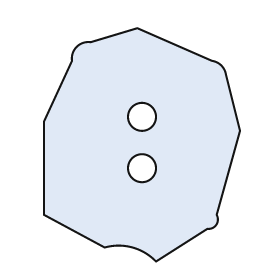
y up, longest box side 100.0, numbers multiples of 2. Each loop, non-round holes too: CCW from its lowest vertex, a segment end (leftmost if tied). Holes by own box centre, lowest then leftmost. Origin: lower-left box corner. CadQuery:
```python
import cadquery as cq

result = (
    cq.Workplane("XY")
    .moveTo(48.0, 0.0)
    .lineTo(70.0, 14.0)
    .threePointArc((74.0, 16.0), (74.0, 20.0))
    .lineTo(84.0, 56.0)
    .lineTo(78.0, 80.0)
    .threePointArc((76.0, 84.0), (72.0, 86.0))
    .lineTo(40.0, 100.0)
    .lineTo(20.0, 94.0)
    .threePointArc((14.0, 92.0), (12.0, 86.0))
    .lineTo(0.0, 60.0)
    .lineTo(0.0, 20.0)
    .lineTo(26.0, 6.0)
    .threePointArc((38.0, 6.0), (48.0, 0.0))
    .close()
    .moveTo(42.0, 40.0)
    .circle(6.0)
    .moveTo(42.0, 62.0)
    .circle(6.0)
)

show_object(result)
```